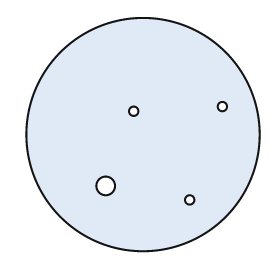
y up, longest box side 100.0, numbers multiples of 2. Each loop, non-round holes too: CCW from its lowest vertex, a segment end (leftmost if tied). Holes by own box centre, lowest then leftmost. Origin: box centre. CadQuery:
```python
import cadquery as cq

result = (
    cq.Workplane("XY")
    .moveTo(0.0, 0.0)
    .circle(50.0)
    .moveTo(20.0, -28.0)
    .circle(2.0)
    .moveTo(-16.0, -22.0)
    .circle(4.0)
    .moveTo(-4.0, 10.0)
    .circle(2.0)
    .moveTo(34.0, 12.0)
    .circle(2.0)
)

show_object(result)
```